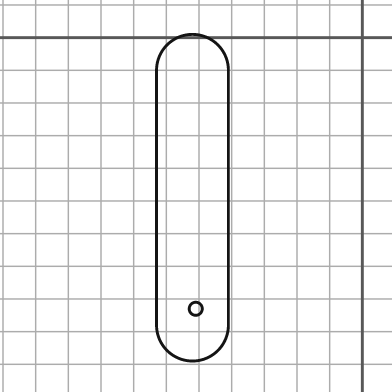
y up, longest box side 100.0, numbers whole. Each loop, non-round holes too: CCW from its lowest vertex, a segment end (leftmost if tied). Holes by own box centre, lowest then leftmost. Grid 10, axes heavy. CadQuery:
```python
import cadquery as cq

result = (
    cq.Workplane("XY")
    .moveTo(-63.0, -88.0)
    .threePointArc((-52.0, -99.0), (-41.0, -88.0))
    .lineTo(-41.0, -10.0)
    .threePointArc((-52.0, 1.0), (-63.0, -10.0))
    .close()
    .moveTo(-51.0, -83.0)
    .circle(2.0)
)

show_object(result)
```